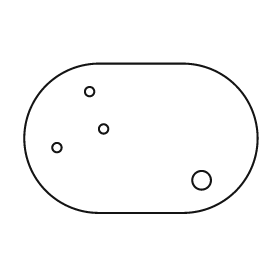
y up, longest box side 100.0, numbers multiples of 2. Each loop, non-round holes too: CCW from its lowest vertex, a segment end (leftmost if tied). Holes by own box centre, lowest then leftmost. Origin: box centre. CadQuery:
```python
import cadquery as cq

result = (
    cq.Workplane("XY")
    .moveTo(-18.0, -32.0)
    .lineTo(18.0, -32.0)
    .threePointArc((50.0, 0.0), (18.0, 32.0))
    .lineTo(-18.0, 32.0)
    .threePointArc((-50.0, 0.0), (-18.0, -32.0))
    .close()
    .moveTo(26.0, -18.0)
    .circle(4.0)
    .moveTo(-36.0, -4.0)
    .circle(2.0)
    .moveTo(-16.0, 4.0)
    .circle(2.0)
    .moveTo(-22.0, 20.0)
    .circle(2.0)
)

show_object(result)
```